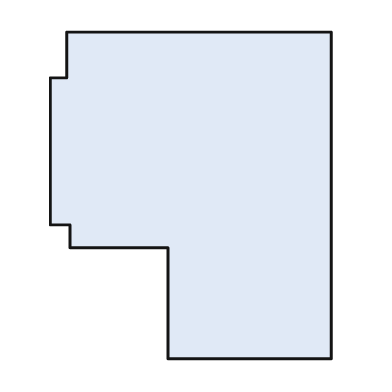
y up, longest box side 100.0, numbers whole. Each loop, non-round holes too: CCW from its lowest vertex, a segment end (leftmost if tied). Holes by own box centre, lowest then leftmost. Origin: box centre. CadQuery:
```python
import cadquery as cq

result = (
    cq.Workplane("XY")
    .moveTo(-7.0, -50.0)
    .lineTo(43.0, -50.0)
    .lineTo(43.0, 50.0)
    .lineTo(-38.0, 50.0)
    .lineTo(-38.0, 36.0)
    .lineTo(-43.0, 36.0)
    .lineTo(-43.0, -9.0)
    .lineTo(-37.0, -9.0)
    .lineTo(-37.0, -16.0)
    .lineTo(-7.0, -16.0)
    .close()
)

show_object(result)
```